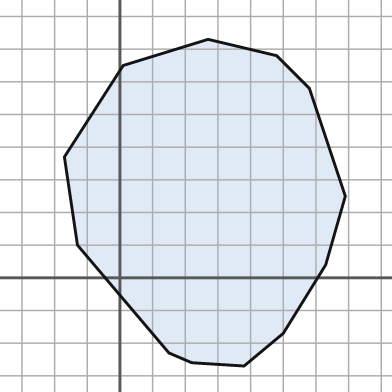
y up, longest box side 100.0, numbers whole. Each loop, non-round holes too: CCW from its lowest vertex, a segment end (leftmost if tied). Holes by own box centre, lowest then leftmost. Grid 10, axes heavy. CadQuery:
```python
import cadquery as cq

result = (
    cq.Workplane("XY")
    .moveTo(38.0, -27.0)
    .lineTo(50.0, -17.0)
    .lineTo(63.0, 4.0)
    .lineTo(69.0, 25.0)
    .lineTo(58.0, 58.0)
    .lineTo(48.0, 68.0)
    .lineTo(27.0, 73.0)
    .lineTo(1.0, 65.0)
    .lineTo(-17.0, 37.0)
    .lineTo(-13.0, 10.0)
    .lineTo(15.0, -23.0)
    .lineTo(22.0, -26.0)
    .close()
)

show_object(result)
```